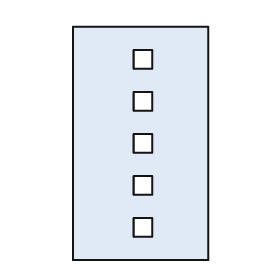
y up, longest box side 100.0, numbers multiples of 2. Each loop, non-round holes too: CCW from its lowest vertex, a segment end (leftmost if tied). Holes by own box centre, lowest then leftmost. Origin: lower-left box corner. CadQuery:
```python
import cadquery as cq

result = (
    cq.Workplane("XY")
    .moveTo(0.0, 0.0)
    .lineTo(58.0, 0.0)
    .lineTo(58.0, 100.0)
    .lineTo(0.0, 100.0)
    .close()
    .moveTo(26.0, 10.0)
    .lineTo(34.0, 10.0)
    .lineTo(34.0, 18.0)
    .lineTo(26.0, 18.0)
    .close()
    .moveTo(26.0, 28.0)
    .lineTo(34.0, 28.0)
    .lineTo(34.0, 36.0)
    .lineTo(26.0, 36.0)
    .close()
    .moveTo(26.0, 46.0)
    .lineTo(34.0, 46.0)
    .lineTo(34.0, 54.0)
    .lineTo(26.0, 54.0)
    .close()
    .moveTo(26.0, 64.0)
    .lineTo(34.0, 64.0)
    .lineTo(34.0, 72.0)
    .lineTo(26.0, 72.0)
    .close()
    .moveTo(26.0, 82.0)
    .lineTo(34.0, 82.0)
    .lineTo(34.0, 90.0)
    .lineTo(26.0, 90.0)
    .close()
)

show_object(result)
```